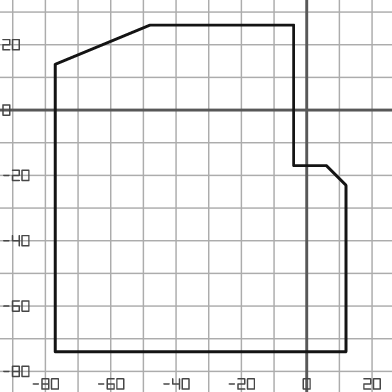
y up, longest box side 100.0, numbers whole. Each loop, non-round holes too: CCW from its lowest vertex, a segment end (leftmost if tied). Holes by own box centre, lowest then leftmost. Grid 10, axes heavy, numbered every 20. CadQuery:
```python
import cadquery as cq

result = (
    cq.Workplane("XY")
    .moveTo(-77.0, -74.0)
    .lineTo(12.0, -74.0)
    .lineTo(12.0, -23.0)
    .lineTo(6.0, -17.0)
    .lineTo(-4.0, -17.0)
    .lineTo(-4.0, 26.0)
    .lineTo(-48.0, 26.0)
    .lineTo(-77.0, 14.0)
    .close()
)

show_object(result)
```